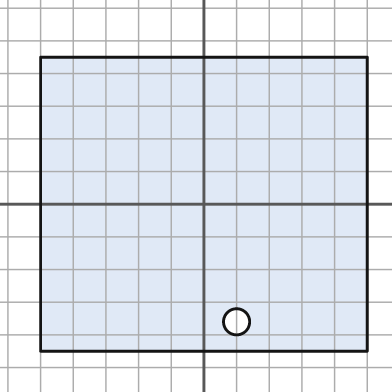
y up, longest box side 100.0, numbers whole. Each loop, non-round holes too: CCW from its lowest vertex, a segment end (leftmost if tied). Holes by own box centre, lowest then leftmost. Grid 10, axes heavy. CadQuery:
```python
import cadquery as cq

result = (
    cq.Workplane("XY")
    .moveTo(-50.0, -45.0)
    .lineTo(50.0, -45.0)
    .lineTo(50.0, 45.0)
    .lineTo(-50.0, 45.0)
    .close()
    .moveTo(10.0, -36.0)
    .circle(4.0)
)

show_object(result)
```